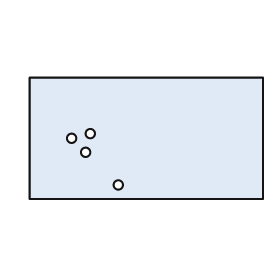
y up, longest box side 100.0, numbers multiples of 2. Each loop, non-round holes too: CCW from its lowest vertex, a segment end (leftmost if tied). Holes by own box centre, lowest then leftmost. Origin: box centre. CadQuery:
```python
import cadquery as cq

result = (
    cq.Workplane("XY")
    .moveTo(-50.0, -26.0)
    .lineTo(50.0, -26.0)
    .lineTo(50.0, 26.0)
    .lineTo(-50.0, 26.0)
    .close()
    .moveTo(-12.0, -20.0)
    .circle(2.0)
    .moveTo(-26.0, -6.0)
    .circle(2.0)
    .moveTo(-32.0, 0.0)
    .circle(2.0)
    .moveTo(-24.0, 2.0)
    .circle(2.0)
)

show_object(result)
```